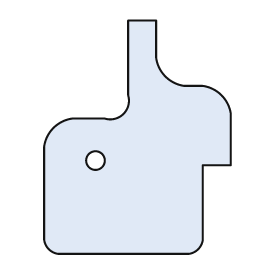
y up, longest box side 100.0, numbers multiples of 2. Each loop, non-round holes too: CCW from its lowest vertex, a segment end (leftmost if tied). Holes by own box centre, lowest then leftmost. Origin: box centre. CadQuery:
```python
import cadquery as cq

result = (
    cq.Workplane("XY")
    .moveTo(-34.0, -50.0)
    .lineTo(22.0, -50.0)
    .threePointArc((26.0, -48.0), (28.0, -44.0))
    .lineTo(28.0, -12.0)
    .lineTo(40.0, -12.0)
    .lineTo(40.0, 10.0)
    .threePointArc((36.0, 18.0), (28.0, 22.0))
    .lineTo(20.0, 22.0)
    .threePointArc((12.0, 26.0), (8.0, 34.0))
    .lineTo(8.0, 50.0)
    .lineTo(-4.0, 50.0)
    .lineTo(-4.0, 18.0)
    .threePointArc((-6.0, 10.0), (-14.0, 8.0))
    .lineTo(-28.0, 8.0)
    .threePointArc((-36.0, 4.0), (-40.0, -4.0))
    .lineTo(-40.0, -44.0)
    .threePointArc((-38.0, -48.0), (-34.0, -50.0))
    .close()
    .moveTo(-18.0, -10.0)
    .circle(4.0)
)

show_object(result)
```